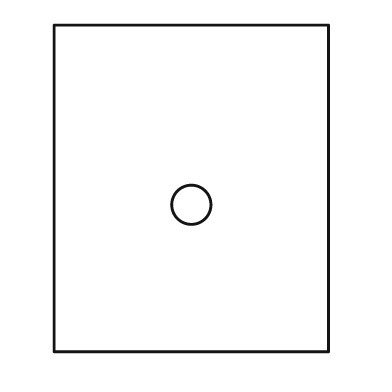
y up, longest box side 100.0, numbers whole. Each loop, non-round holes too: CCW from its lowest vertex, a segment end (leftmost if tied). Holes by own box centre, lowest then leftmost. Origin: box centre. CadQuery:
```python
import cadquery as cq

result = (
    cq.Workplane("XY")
    .moveTo(-42.0, -50.0)
    .lineTo(42.0, -50.0)
    .lineTo(42.0, 50.0)
    .lineTo(-42.0, 50.0)
    .close()
    .moveTo(0.0, -5.0)
    .circle(6.0)
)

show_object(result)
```